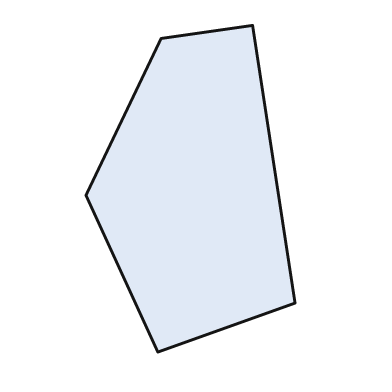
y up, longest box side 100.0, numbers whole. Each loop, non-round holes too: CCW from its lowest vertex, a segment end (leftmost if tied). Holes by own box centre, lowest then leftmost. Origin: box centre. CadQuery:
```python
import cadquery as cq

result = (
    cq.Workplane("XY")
    .moveTo(-10.0, -50.0)
    .lineTo(32.0, -35.0)
    .lineTo(19.0, 50.0)
    .lineTo(-9.0, 46.0)
    .lineTo(-32.0, -2.0)
    .close()
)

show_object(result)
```